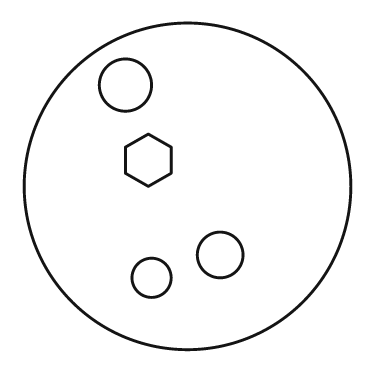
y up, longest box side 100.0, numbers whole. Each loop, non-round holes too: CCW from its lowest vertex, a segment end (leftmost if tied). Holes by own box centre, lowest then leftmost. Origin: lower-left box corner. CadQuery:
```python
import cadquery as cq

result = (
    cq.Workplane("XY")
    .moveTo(50.0, 50.0)
    .circle(50.0)
    .moveTo(39.0, 22.0)
    .circle(6.0)
    .moveTo(60.0, 29.0)
    .circle(7.0)
    .moveTo(38.0, 50.0)
    .lineTo(45.0, 54.0)
    .lineTo(45.0, 62.0)
    .lineTo(38.0, 66.0)
    .lineTo(31.0, 62.0)
    .lineTo(31.0, 54.0)
    .close()
    .moveTo(31.0, 81.0)
    .circle(8.0)
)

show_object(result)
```